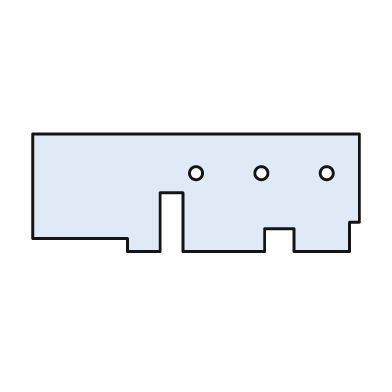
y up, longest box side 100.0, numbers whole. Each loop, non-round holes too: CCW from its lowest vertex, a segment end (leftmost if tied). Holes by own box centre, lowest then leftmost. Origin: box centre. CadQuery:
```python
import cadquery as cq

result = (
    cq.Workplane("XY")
    .moveTo(-21.0, -18.0)
    .lineTo(-11.0, -18.0)
    .lineTo(-11.0, 0.0)
    .lineTo(-4.0, 0.0)
    .lineTo(-4.0, -18.0)
    .lineTo(21.0, -18.0)
    .lineTo(21.0, -11.0)
    .lineTo(30.0, -11.0)
    .lineTo(30.0, -18.0)
    .lineTo(47.0, -18.0)
    .lineTo(47.0, -9.0)
    .lineTo(50.0, -9.0)
    .lineTo(50.0, 18.0)
    .lineTo(-50.0, 18.0)
    .lineTo(-50.0, -14.0)
    .lineTo(-21.0, -14.0)
    .close()
    .moveTo(0.0, 6.0)
    .circle(2.0)
    .moveTo(20.0, 6.0)
    .circle(2.0)
    .moveTo(40.0, 6.0)
    .circle(2.0)
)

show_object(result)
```